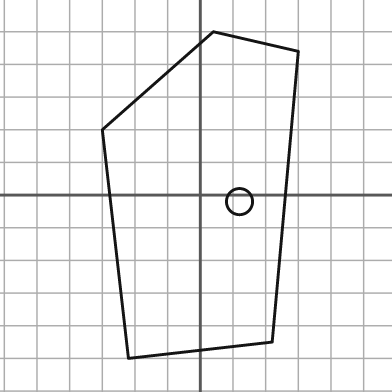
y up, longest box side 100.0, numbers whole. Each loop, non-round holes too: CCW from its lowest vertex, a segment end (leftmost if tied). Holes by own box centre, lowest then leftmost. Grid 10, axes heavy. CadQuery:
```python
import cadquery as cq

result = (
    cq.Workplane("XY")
    .moveTo(-22.0, -50.0)
    .lineTo(22.0, -45.0)
    .lineTo(30.0, 44.0)
    .lineTo(4.0, 50.0)
    .lineTo(-30.0, 20.0)
    .close()
    .moveTo(12.0, -2.0)
    .circle(4.0)
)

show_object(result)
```